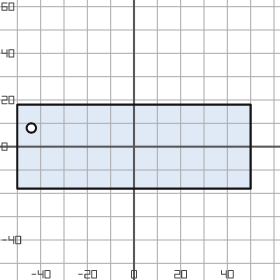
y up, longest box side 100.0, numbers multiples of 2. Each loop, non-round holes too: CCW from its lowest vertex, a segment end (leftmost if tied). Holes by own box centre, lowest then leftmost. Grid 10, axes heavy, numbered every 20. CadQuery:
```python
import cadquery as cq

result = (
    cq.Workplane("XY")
    .moveTo(-50.0, -18.0)
    .lineTo(50.0, -18.0)
    .lineTo(50.0, 18.0)
    .lineTo(-50.0, 18.0)
    .close()
    .moveTo(-44.0, 8.0)
    .circle(2.0)
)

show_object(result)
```